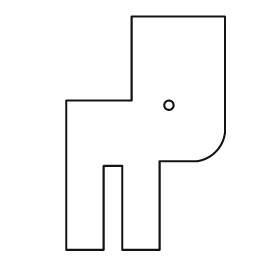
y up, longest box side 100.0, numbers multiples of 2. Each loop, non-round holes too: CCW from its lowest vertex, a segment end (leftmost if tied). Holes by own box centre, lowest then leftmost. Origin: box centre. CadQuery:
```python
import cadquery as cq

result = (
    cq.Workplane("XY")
    .moveTo(-34.0, -50.0)
    .lineTo(-18.0, -50.0)
    .lineTo(-18.0, -14.0)
    .lineTo(-10.0, -14.0)
    .lineTo(-10.0, -50.0)
    .lineTo(6.0, -50.0)
    .lineTo(6.0, -12.0)
    .lineTo(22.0, -12.0)
    .threePointArc((30.0, -8.0), (34.0, 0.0))
    .lineTo(34.0, 50.0)
    .lineTo(-6.0, 50.0)
    .lineTo(-6.0, 14.0)
    .lineTo(-34.0, 14.0)
    .close()
    .moveTo(10.0, 12.0)
    .circle(2.0)
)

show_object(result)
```